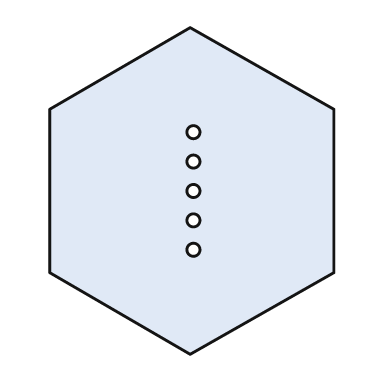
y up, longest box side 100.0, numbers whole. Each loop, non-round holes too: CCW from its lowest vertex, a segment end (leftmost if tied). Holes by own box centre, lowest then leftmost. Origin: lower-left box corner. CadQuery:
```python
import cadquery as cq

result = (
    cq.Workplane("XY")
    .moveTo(43.0, 0.0)
    .lineTo(87.0, 25.0)
    .lineTo(87.0, 75.0)
    .lineTo(43.0, 100.0)
    .lineTo(0.0, 75.0)
    .lineTo(0.0, 25.0)
    .close()
    .moveTo(44.0, 32.0)
    .circle(2.0)
    .moveTo(44.0, 41.0)
    .circle(2.0)
    .moveTo(44.0, 50.0)
    .circle(2.0)
    .moveTo(44.0, 59.0)
    .circle(2.0)
    .moveTo(44.0, 68.0)
    .circle(2.0)
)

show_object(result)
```